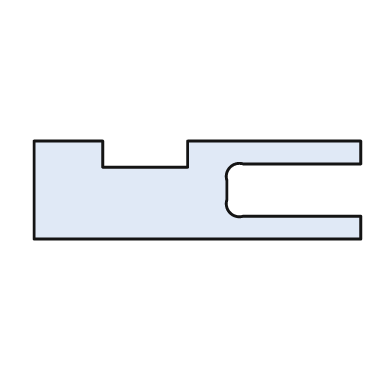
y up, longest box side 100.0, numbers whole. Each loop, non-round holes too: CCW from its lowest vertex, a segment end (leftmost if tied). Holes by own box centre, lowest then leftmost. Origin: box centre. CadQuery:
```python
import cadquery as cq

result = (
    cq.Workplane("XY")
    .moveTo(-50.0, -15.0)
    .lineTo(50.0, -15.0)
    .lineTo(50.0, -8.0)
    .lineTo(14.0, -8.0)
    .threePointArc((10.0, -7.0), (9.0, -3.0))
    .lineTo(9.0, 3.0)
    .threePointArc((10.0, 7.0), (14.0, 8.0))
    .lineTo(50.0, 8.0)
    .lineTo(50.0, 15.0)
    .lineTo(-3.0, 15.0)
    .lineTo(-3.0, 7.0)
    .lineTo(-29.0, 7.0)
    .lineTo(-29.0, 15.0)
    .lineTo(-50.0, 15.0)
    .close()
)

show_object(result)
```